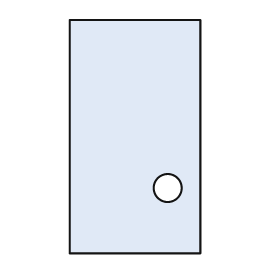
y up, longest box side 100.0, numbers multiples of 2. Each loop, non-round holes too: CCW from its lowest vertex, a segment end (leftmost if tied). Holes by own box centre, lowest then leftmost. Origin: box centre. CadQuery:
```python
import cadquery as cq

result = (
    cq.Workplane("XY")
    .moveTo(-28.0, -50.0)
    .lineTo(28.0, -50.0)
    .lineTo(28.0, 50.0)
    .lineTo(-28.0, 50.0)
    .close()
    .moveTo(14.0, -22.0)
    .circle(6.0)
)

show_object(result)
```